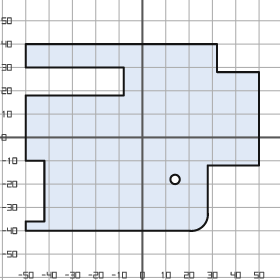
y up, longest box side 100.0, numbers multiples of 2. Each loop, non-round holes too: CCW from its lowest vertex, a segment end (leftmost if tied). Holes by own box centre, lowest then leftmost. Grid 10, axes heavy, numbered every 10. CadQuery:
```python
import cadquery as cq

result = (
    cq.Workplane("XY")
    .moveTo(-50.0, -40.0)
    .lineTo(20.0, -40.0)
    .threePointArc((26.0, -38.0), (28.0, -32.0))
    .lineTo(28.0, -12.0)
    .lineTo(50.0, -12.0)
    .lineTo(50.0, 28.0)
    .lineTo(32.0, 28.0)
    .lineTo(32.0, 40.0)
    .lineTo(-50.0, 40.0)
    .lineTo(-50.0, 30.0)
    .lineTo(-8.0, 30.0)
    .lineTo(-8.0, 18.0)
    .lineTo(-50.0, 18.0)
    .lineTo(-50.0, -10.0)
    .lineTo(-42.0, -10.0)
    .lineTo(-42.0, -36.0)
    .lineTo(-50.0, -36.0)
    .close()
    .moveTo(14.0, -18.0)
    .circle(2.0)
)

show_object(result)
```